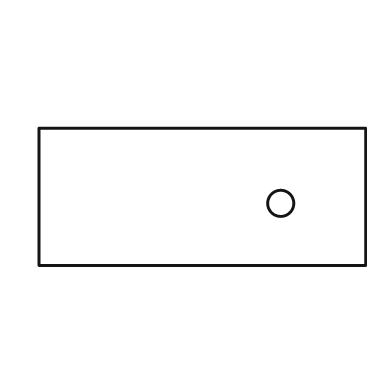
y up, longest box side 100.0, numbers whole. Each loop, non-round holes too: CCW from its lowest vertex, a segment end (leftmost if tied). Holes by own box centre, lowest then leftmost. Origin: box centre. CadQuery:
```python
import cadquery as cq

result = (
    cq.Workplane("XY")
    .moveTo(-50.0, -21.0)
    .lineTo(50.0, -21.0)
    .lineTo(50.0, 21.0)
    .lineTo(-50.0, 21.0)
    .close()
    .moveTo(24.0, -2.0)
    .circle(4.0)
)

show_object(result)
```